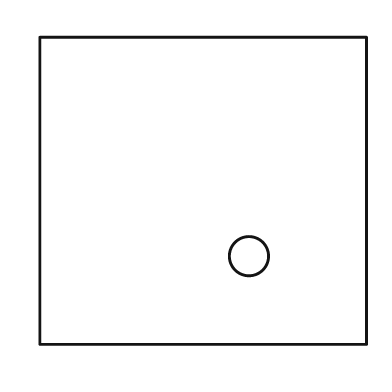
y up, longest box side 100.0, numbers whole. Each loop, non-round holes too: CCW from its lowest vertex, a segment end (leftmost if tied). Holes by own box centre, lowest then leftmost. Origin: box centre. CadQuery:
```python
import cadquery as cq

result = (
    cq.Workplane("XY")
    .moveTo(-50.0, -47.0)
    .lineTo(50.0, -47.0)
    .lineTo(50.0, 47.0)
    .lineTo(-50.0, 47.0)
    .close()
    .moveTo(14.0, -20.0)
    .circle(6.0)
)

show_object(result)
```